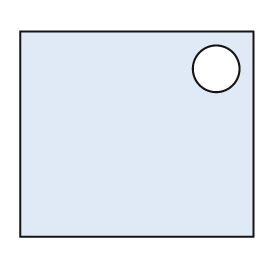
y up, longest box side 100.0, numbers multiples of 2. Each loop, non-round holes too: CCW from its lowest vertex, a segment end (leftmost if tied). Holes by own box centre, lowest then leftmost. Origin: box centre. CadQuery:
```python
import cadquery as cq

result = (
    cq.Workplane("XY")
    .moveTo(-50.0, -44.0)
    .lineTo(50.0, -44.0)
    .lineTo(50.0, 44.0)
    .lineTo(-50.0, 44.0)
    .close()
    .moveTo(34.0, 28.0)
    .circle(10.0)
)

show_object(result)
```